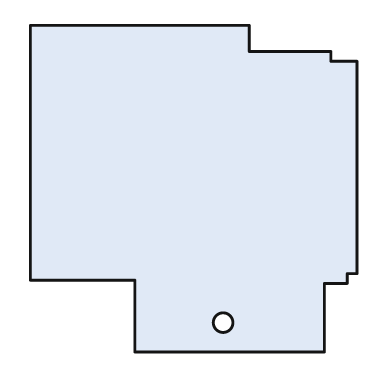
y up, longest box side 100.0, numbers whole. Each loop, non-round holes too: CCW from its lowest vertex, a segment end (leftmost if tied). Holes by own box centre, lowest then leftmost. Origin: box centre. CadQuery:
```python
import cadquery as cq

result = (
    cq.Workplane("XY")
    .moveTo(-18.0, -50.0)
    .lineTo(40.0, -50.0)
    .lineTo(40.0, -29.0)
    .lineTo(47.0, -29.0)
    .lineTo(47.0, -26.0)
    .lineTo(50.0, -26.0)
    .lineTo(50.0, 39.0)
    .lineTo(42.0, 39.0)
    .lineTo(42.0, 42.0)
    .lineTo(17.0, 42.0)
    .lineTo(17.0, 50.0)
    .lineTo(-50.0, 50.0)
    .lineTo(-50.0, -28.0)
    .lineTo(-18.0, -28.0)
    .close()
    .moveTo(9.0, -41.0)
    .circle(3.0)
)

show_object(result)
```